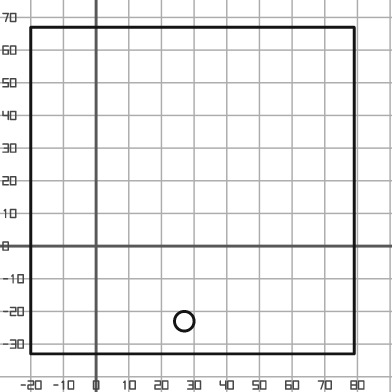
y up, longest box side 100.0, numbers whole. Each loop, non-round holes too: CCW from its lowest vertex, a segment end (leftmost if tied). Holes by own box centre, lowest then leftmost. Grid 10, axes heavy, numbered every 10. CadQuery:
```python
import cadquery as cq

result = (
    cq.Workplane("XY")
    .moveTo(-20.0, -33.0)
    .lineTo(79.0, -33.0)
    .lineTo(79.0, 67.0)
    .lineTo(-20.0, 67.0)
    .close()
    .moveTo(27.0, -23.0)
    .circle(3.0)
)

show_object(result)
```